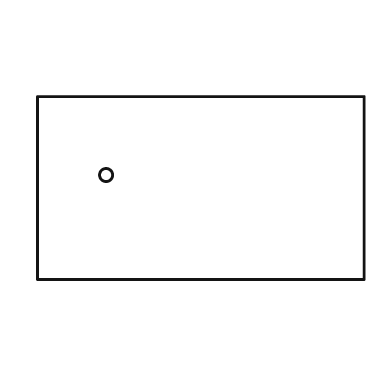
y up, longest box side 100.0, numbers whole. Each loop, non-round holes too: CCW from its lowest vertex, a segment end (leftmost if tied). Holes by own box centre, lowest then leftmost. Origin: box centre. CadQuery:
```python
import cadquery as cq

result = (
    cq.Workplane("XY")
    .moveTo(-50.0, -28.0)
    .lineTo(50.0, -28.0)
    .lineTo(50.0, 28.0)
    .lineTo(-50.0, 28.0)
    .close()
    .moveTo(-29.0, 4.0)
    .circle(2.0)
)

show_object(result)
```